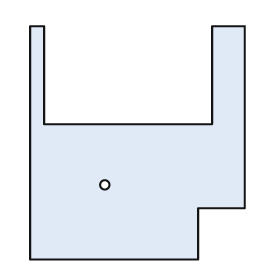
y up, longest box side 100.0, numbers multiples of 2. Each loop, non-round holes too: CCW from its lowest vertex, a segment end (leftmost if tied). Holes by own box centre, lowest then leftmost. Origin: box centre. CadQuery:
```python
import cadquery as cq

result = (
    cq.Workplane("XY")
    .moveTo(-46.0, -50.0)
    .lineTo(26.0, -50.0)
    .lineTo(26.0, -28.0)
    .lineTo(46.0, -28.0)
    .lineTo(46.0, 50.0)
    .lineTo(32.0, 50.0)
    .lineTo(32.0, 8.0)
    .lineTo(-40.0, 8.0)
    .lineTo(-40.0, 50.0)
    .lineTo(-46.0, 50.0)
    .close()
    .moveTo(-14.0, -18.0)
    .circle(2.0)
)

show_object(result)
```